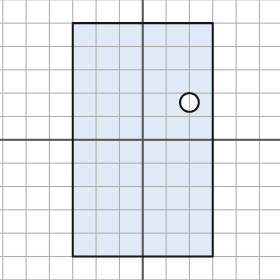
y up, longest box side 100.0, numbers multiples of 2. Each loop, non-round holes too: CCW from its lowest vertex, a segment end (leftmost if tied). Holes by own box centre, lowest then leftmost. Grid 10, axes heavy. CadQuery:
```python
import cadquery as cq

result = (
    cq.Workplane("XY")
    .moveTo(-30.0, -50.0)
    .lineTo(30.0, -50.0)
    .lineTo(30.0, 50.0)
    .lineTo(-30.0, 50.0)
    .close()
    .moveTo(20.0, 16.0)
    .circle(4.0)
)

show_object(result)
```